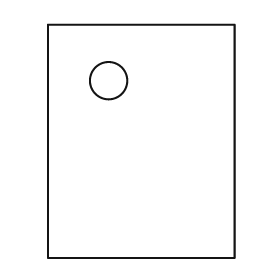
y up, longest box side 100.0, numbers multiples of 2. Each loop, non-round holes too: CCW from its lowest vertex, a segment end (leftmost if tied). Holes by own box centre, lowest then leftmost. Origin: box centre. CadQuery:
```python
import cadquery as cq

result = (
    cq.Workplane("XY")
    .moveTo(-40.0, -50.0)
    .lineTo(40.0, -50.0)
    .lineTo(40.0, 50.0)
    .lineTo(-40.0, 50.0)
    .close()
    .moveTo(-14.0, 26.0)
    .circle(8.0)
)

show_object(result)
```